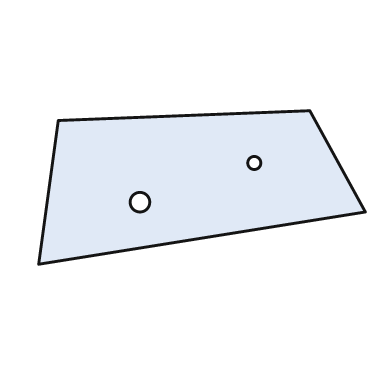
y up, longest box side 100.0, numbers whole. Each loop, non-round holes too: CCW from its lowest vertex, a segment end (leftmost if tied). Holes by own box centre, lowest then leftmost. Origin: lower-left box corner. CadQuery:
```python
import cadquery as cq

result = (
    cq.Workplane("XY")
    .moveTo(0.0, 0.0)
    .lineTo(100.0, 16.0)
    .lineTo(83.0, 47.0)
    .lineTo(6.0, 44.0)
    .close()
    .moveTo(31.0, 19.0)
    .circle(3.0)
    .moveTo(66.0, 31.0)
    .circle(2.0)
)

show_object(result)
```